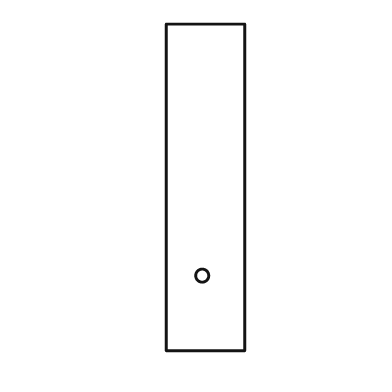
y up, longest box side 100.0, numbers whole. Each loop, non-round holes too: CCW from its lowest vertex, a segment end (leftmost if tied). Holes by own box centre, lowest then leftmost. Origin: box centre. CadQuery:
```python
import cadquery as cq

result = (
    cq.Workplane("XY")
    .moveTo(-12.0, -50.0)
    .lineTo(12.0, -50.0)
    .lineTo(12.0, 50.0)
    .lineTo(-12.0, 50.0)
    .close()
    .moveTo(-1.0, -27.0)
    .circle(2.0)
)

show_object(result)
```